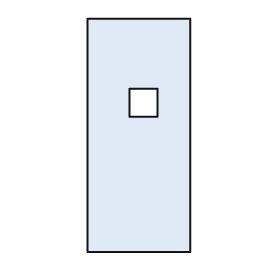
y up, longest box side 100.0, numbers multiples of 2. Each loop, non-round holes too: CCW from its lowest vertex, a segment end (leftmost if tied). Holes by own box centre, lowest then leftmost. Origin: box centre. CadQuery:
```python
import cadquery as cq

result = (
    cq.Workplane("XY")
    .moveTo(-22.0, -50.0)
    .lineTo(22.0, -50.0)
    .lineTo(22.0, 50.0)
    .lineTo(-22.0, 50.0)
    .close()
    .moveTo(-4.0, 8.0)
    .lineTo(8.0, 8.0)
    .lineTo(8.0, 20.0)
    .lineTo(-4.0, 20.0)
    .close()
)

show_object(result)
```